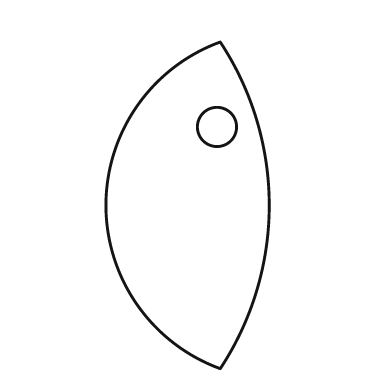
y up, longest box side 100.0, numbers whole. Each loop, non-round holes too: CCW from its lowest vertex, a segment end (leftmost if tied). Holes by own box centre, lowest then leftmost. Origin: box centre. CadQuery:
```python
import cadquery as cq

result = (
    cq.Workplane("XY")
    .moveTo(10.0, -50.0)
    .threePointArc((25.0, 0.0), (10.0, 50.0))
    .threePointArc((-25.0, 0.0), (10.0, -50.0))
    .close()
    .moveTo(9.0, 24.0)
    .circle(6.0)
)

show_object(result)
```